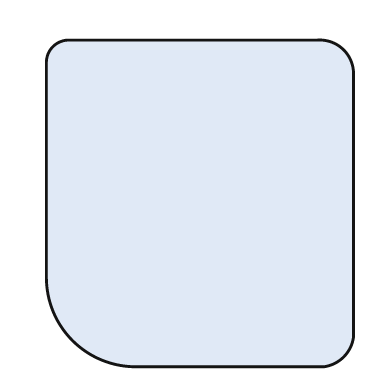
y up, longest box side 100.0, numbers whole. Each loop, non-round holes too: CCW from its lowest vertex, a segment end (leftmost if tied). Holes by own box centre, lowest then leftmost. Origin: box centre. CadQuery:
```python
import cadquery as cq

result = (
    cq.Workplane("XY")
    .moveTo(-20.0, -50.0)
    .lineTo(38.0, -50.0)
    .threePointArc((44.0, -47.0), (47.0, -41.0))
    .lineTo(47.0, 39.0)
    .threePointArc((44.0, 47.0), (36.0, 50.0))
    .lineTo(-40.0, 50.0)
    .threePointArc((-45.0, 48.0), (-47.0, 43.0))
    .lineTo(-47.0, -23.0)
    .threePointArc((-39.0, -42.0), (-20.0, -50.0))
    .close()
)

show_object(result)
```